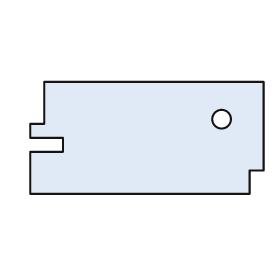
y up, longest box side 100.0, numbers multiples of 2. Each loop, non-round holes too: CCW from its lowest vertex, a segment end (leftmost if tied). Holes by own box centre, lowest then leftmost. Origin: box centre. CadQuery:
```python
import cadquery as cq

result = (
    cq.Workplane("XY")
    .moveTo(-50.0, -24.0)
    .lineTo(44.0, -24.0)
    .lineTo(44.0, -14.0)
    .lineTo(50.0, -14.0)
    .lineTo(50.0, 24.0)
    .lineTo(-44.0, 24.0)
    .lineTo(-44.0, 6.0)
    .lineTo(-50.0, 6.0)
    .lineTo(-50.0, 0.0)
    .lineTo(-36.0, 0.0)
    .lineTo(-36.0, -6.0)
    .lineTo(-50.0, -6.0)
    .close()
    .moveTo(32.0, 8.0)
    .circle(4.0)
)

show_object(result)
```